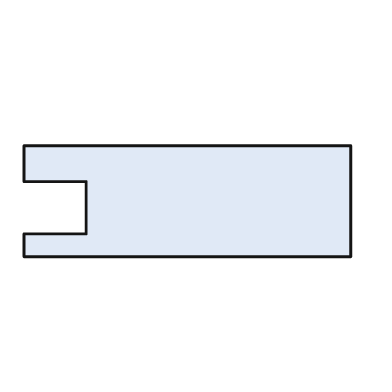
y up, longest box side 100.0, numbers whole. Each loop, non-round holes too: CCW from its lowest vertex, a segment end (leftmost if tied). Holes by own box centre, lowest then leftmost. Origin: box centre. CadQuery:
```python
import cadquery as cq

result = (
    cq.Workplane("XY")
    .moveTo(-50.0, -17.0)
    .lineTo(50.0, -17.0)
    .lineTo(50.0, 17.0)
    .lineTo(-50.0, 17.0)
    .lineTo(-50.0, 6.0)
    .lineTo(-31.0, 6.0)
    .lineTo(-31.0, -10.0)
    .lineTo(-50.0, -10.0)
    .close()
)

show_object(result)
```